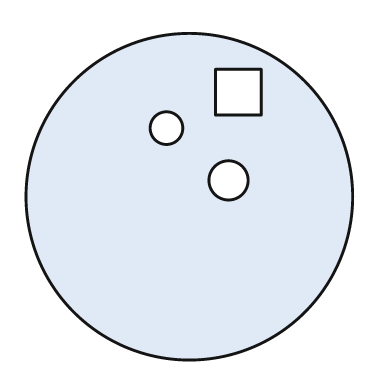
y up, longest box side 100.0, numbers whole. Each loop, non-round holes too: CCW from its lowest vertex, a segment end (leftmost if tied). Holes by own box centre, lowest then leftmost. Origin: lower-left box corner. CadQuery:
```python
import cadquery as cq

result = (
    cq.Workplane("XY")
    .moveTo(50.0, 50.0)
    .circle(50.0)
    .moveTo(62.0, 55.0)
    .circle(6.0)
    .moveTo(43.0, 71.0)
    .circle(5.0)
    .moveTo(58.0, 75.0)
    .lineTo(72.0, 75.0)
    .lineTo(72.0, 89.0)
    .lineTo(58.0, 89.0)
    .close()
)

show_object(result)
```